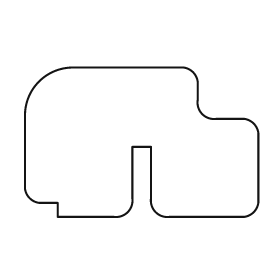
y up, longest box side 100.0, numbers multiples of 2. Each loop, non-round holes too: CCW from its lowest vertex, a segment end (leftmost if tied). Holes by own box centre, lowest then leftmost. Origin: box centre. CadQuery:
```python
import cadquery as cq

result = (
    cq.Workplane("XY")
    .moveTo(-36.0, -32.0)
    .lineTo(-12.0, -32.0)
    .threePointArc((-6.0, -30.0), (-4.0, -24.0))
    .lineTo(-4.0, -2.0)
    .lineTo(4.0, -2.0)
    .lineTo(4.0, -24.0)
    .threePointArc((6.0, -30.0), (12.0, -32.0))
    .lineTo(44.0, -32.0)
    .threePointArc((48.0, -30.0), (50.0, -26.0))
    .lineTo(50.0, 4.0)
    .threePointArc((48.0, 8.0), (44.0, 10.0))
    .lineTo(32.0, 10.0)
    .threePointArc((26.0, 12.0), (24.0, 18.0))
    .lineTo(24.0, 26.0)
    .threePointArc((22.0, 30.0), (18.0, 32.0))
    .lineTo(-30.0, 32.0)
    .threePointArc((-44.0, 26.0), (-50.0, 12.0))
    .lineTo(-50.0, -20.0)
    .threePointArc((-48.0, -24.0), (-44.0, -26.0))
    .lineTo(-36.0, -26.0)
    .close()
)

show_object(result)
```